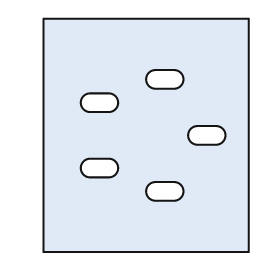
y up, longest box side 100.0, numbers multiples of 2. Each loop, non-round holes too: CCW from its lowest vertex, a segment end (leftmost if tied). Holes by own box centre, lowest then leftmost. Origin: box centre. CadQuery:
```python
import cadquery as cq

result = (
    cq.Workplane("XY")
    .moveTo(-44.0, -50.0)
    .lineTo(44.0, -50.0)
    .lineTo(44.0, 50.0)
    .lineTo(-44.0, 50.0)
    .close()
    .moveTo(4.0, -28.0)
    .lineTo(12.0, -28.0)
    .threePointArc((16.0, -24.0), (12.0, -20.0))
    .lineTo(4.0, -20.0)
    .threePointArc((0.0, -24.0), (4.0, -28.0))
    .close()
    .moveTo(-24.0, -18.0)
    .lineTo(-16.0, -18.0)
    .threePointArc((-12.0, -14.0), (-16.0, -10.0))
    .lineTo(-24.0, -10.0)
    .threePointArc((-28.0, -14.0), (-24.0, -18.0))
    .close()
    .moveTo(22.0, -4.0)
    .lineTo(30.0, -4.0)
    .threePointArc((34.0, 0.0), (30.0, 4.0))
    .lineTo(22.0, 4.0)
    .threePointArc((18.0, 0.0), (22.0, -4.0))
    .close()
    .moveTo(-24.0, 10.0)
    .lineTo(-16.0, 10.0)
    .threePointArc((-12.0, 14.0), (-16.0, 18.0))
    .lineTo(-24.0, 18.0)
    .threePointArc((-28.0, 14.0), (-24.0, 10.0))
    .close()
    .moveTo(4.0, 20.0)
    .lineTo(12.0, 20.0)
    .threePointArc((16.0, 24.0), (12.0, 28.0))
    .lineTo(4.0, 28.0)
    .threePointArc((0.0, 24.0), (4.0, 20.0))
    .close()
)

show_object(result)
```